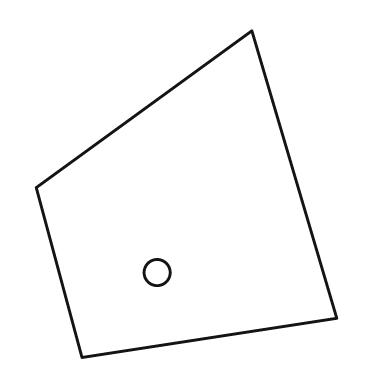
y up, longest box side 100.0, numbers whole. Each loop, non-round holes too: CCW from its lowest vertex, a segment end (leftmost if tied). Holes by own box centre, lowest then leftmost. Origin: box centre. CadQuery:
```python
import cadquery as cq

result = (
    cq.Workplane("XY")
    .moveTo(-32.0, -50.0)
    .lineTo(46.0, -38.0)
    .lineTo(20.0, 50.0)
    .lineTo(-46.0, 2.0)
    .close()
    .moveTo(-9.0, -24.0)
    .circle(4.0)
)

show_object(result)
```